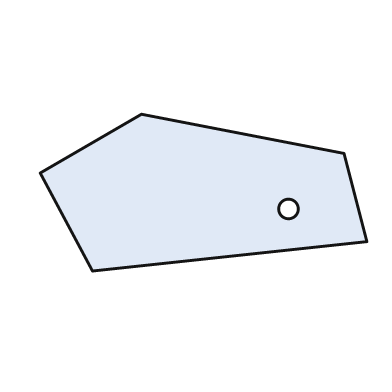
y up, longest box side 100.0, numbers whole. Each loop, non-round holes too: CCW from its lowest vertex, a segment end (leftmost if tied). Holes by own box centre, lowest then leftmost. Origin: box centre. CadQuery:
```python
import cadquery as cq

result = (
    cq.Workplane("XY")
    .moveTo(-34.0, -24.0)
    .lineTo(50.0, -15.0)
    .lineTo(43.0, 12.0)
    .lineTo(-19.0, 24.0)
    .lineTo(-50.0, 6.0)
    .close()
    .moveTo(26.0, -5.0)
    .circle(3.0)
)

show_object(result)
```